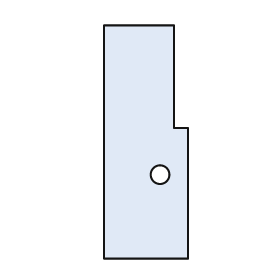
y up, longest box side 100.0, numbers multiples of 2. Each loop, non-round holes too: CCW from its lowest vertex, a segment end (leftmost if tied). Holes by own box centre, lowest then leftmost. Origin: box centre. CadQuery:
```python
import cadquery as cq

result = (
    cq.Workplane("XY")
    .moveTo(-18.0, -50.0)
    .lineTo(18.0, -50.0)
    .lineTo(18.0, 6.0)
    .lineTo(12.0, 6.0)
    .lineTo(12.0, 50.0)
    .lineTo(-18.0, 50.0)
    .close()
    .moveTo(6.0, -14.0)
    .circle(4.0)
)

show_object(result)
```